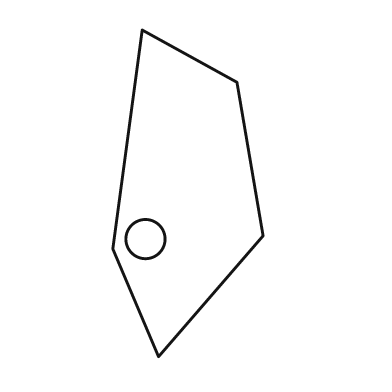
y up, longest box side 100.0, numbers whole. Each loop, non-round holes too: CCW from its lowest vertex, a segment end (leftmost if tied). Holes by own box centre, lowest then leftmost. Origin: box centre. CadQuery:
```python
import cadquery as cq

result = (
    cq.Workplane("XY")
    .moveTo(-9.0, -50.0)
    .lineTo(23.0, -13.0)
    .lineTo(15.0, 34.0)
    .lineTo(-14.0, 50.0)
    .lineTo(-23.0, -17.0)
    .close()
    .moveTo(-13.0, -14.0)
    .circle(6.0)
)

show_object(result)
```